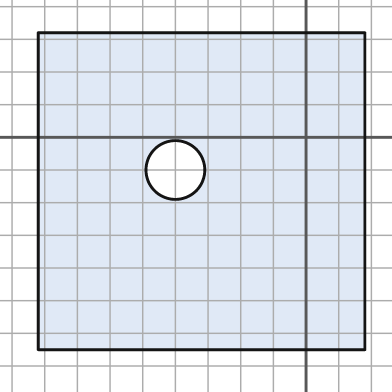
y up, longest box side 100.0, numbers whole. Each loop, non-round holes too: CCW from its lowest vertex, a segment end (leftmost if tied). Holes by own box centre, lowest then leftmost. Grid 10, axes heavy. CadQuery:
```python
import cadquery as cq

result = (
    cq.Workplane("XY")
    .moveTo(-82.0, -65.0)
    .lineTo(18.0, -65.0)
    .lineTo(18.0, 32.0)
    .lineTo(-82.0, 32.0)
    .close()
    .moveTo(-40.0, -10.0)
    .circle(9.0)
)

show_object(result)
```